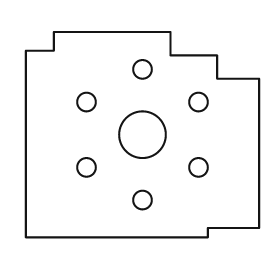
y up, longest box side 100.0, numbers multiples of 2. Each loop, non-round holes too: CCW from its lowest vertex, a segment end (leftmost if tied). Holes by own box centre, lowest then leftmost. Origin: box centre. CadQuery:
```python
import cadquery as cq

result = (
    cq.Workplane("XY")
    .moveTo(-50.0, -44.0)
    .lineTo(28.0, -44.0)
    .lineTo(28.0, -40.0)
    .lineTo(50.0, -40.0)
    .lineTo(50.0, 24.0)
    .lineTo(32.0, 24.0)
    .lineTo(32.0, 34.0)
    .lineTo(12.0, 34.0)
    .lineTo(12.0, 44.0)
    .lineTo(-38.0, 44.0)
    .lineTo(-38.0, 36.0)
    .lineTo(-50.0, 36.0)
    .close()
    .moveTo(0.0, -28.0)
    .circle(4.0)
    .moveTo(-24.0, -14.0)
    .circle(4.0)
    .moveTo(24.0, -14.0)
    .circle(4.0)
    .moveTo(0.0, 0.0)
    .circle(10.0)
    .moveTo(-24.0, 14.0)
    .circle(4.0)
    .moveTo(24.0, 14.0)
    .circle(4.0)
    .moveTo(0.0, 28.0)
    .circle(4.0)
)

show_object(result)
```